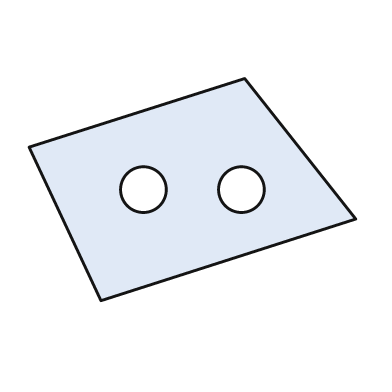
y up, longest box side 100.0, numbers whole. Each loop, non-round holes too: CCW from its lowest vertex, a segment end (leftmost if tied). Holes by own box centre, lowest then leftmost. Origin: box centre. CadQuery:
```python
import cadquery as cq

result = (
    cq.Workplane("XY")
    .moveTo(-28.0, -34.0)
    .lineTo(50.0, -9.0)
    .lineTo(16.0, 34.0)
    .lineTo(-50.0, 13.0)
    .close()
    .moveTo(-15.0, 0.0)
    .circle(7.0)
    .moveTo(15.0, 0.0)
    .circle(7.0)
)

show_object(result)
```